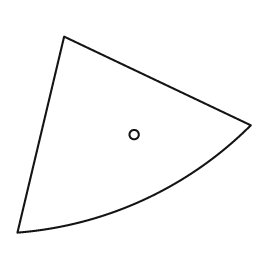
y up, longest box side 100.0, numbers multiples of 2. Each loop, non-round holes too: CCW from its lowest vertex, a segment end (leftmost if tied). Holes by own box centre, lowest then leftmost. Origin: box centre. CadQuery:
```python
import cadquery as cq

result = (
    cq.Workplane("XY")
    .moveTo(-50.0, -42.0)
    .threePointArc((4.0, -28.0), (50.0, 4.0))
    .lineTo(-30.0, 42.0)
    .close()
    .moveTo(0.0, 0.0)
    .circle(2.0)
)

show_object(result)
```